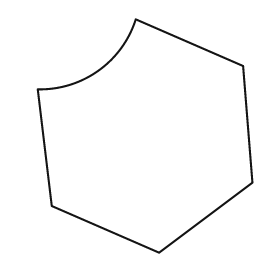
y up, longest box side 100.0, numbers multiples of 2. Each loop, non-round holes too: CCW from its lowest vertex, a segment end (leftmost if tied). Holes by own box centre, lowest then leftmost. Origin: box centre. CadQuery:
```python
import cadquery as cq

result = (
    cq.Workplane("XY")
    .moveTo(6.0, -50.0)
    .lineTo(46.0, -20.0)
    .lineTo(42.0, 30.0)
    .lineTo(-4.0, 50.0)
    .threePointArc((-20.0, 28.0), (-46.0, 20.0))
    .lineTo(-40.0, -30.0)
    .close()
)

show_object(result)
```